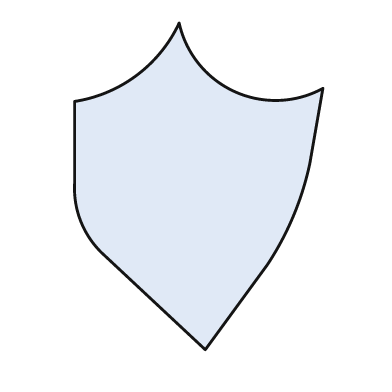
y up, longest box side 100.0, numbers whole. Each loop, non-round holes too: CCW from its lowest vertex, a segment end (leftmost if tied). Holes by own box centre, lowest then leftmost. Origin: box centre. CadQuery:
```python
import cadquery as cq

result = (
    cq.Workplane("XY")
    .moveTo(2.0, -50.0)
    .lineTo(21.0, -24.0)
    .threePointArc((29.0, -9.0), (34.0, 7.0))
    .lineTo(38.0, 30.0)
    .threePointArc((11.0, 29.0), (-6.0, 50.0))
    .threePointArc((-19.0, 34.0), (-38.0, 26.0))
    .lineTo(-38.0, 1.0)
    .threePointArc((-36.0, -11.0), (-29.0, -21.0))
    .close()
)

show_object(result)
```